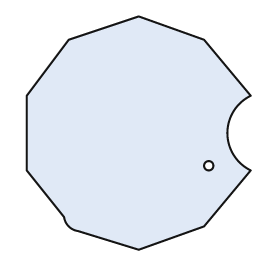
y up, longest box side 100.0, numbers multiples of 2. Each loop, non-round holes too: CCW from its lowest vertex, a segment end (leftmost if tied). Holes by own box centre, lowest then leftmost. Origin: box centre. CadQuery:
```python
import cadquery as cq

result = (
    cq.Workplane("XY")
    .moveTo(0.0, -50.0)
    .lineTo(28.0, -40.0)
    .lineTo(48.0, -16.0)
    .threePointArc((38.0, 0.0), (48.0, 16.0))
    .lineTo(28.0, 40.0)
    .lineTo(0.0, 50.0)
    .lineTo(-30.0, 40.0)
    .lineTo(-48.0, 16.0)
    .lineTo(-48.0, -16.0)
    .lineTo(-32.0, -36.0)
    .threePointArc((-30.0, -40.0), (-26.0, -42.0))
    .close()
    .moveTo(30.0, -14.0)
    .circle(2.0)
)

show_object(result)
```